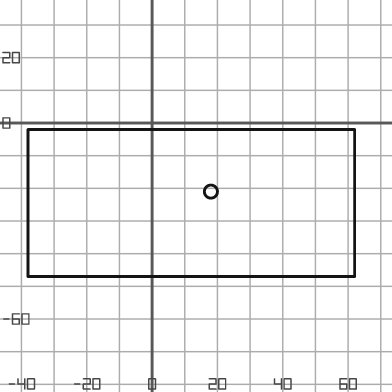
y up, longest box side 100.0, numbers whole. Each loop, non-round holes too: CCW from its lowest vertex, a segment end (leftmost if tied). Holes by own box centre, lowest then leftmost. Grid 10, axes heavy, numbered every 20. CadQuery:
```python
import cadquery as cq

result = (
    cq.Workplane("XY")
    .moveTo(-38.0, -47.0)
    .lineTo(62.0, -47.0)
    .lineTo(62.0, -2.0)
    .lineTo(-38.0, -2.0)
    .close()
    .moveTo(18.0, -21.0)
    .circle(2.0)
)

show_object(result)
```